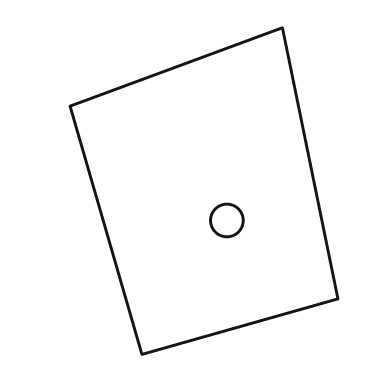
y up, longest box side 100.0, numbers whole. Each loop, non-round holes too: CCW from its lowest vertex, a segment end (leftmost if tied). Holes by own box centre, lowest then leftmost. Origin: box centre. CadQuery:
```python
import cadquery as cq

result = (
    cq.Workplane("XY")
    .moveTo(-19.0, -50.0)
    .lineTo(41.0, -33.0)
    .lineTo(24.0, 50.0)
    .lineTo(-41.0, 26.0)
    .close()
    .moveTo(7.0, -9.0)
    .circle(5.0)
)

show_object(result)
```